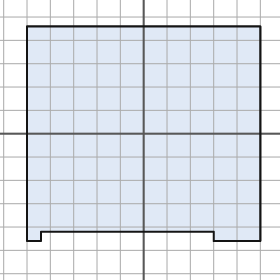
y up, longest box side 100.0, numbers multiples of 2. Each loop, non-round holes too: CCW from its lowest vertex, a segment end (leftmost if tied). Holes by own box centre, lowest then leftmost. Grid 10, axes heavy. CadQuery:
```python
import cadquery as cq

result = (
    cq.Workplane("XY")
    .moveTo(-50.0, -46.0)
    .lineTo(-44.0, -46.0)
    .lineTo(-44.0, -42.0)
    .lineTo(30.0, -42.0)
    .lineTo(30.0, -46.0)
    .lineTo(50.0, -46.0)
    .lineTo(50.0, 46.0)
    .lineTo(-50.0, 46.0)
    .close()
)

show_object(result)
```